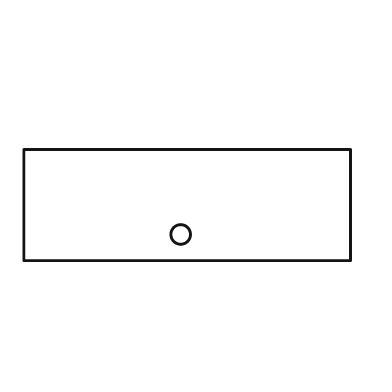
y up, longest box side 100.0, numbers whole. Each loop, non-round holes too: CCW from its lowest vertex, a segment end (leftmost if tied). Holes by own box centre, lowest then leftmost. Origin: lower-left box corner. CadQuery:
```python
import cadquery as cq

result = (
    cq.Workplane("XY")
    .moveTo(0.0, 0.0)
    .lineTo(100.0, 0.0)
    .lineTo(100.0, 34.0)
    .lineTo(0.0, 34.0)
    .close()
    .moveTo(48.0, 8.0)
    .circle(3.0)
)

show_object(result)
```